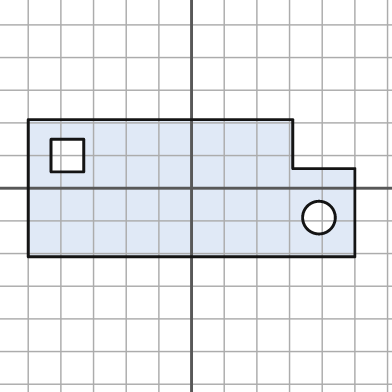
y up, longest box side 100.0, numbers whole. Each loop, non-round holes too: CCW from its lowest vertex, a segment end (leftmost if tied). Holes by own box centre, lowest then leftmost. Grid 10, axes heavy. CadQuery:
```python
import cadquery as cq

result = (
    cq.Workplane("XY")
    .moveTo(-50.0, -21.0)
    .lineTo(50.0, -21.0)
    .lineTo(50.0, 6.0)
    .lineTo(31.0, 6.0)
    .lineTo(31.0, 21.0)
    .lineTo(-50.0, 21.0)
    .close()
    .moveTo(39.0, -9.0)
    .circle(5.0)
    .moveTo(-43.0, 5.0)
    .lineTo(-33.0, 5.0)
    .lineTo(-33.0, 15.0)
    .lineTo(-43.0, 15.0)
    .close()
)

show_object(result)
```